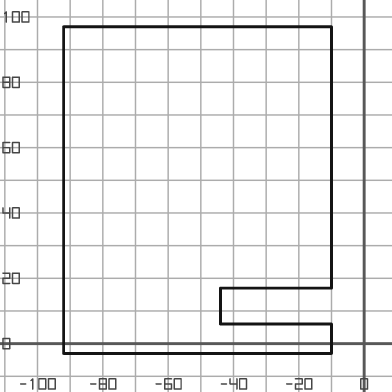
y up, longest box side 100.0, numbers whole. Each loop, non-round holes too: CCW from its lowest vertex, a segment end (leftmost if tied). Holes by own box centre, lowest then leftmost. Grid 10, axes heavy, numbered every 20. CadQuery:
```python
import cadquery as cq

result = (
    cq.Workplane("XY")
    .moveTo(-92.0, -3.0)
    .lineTo(-10.0, -3.0)
    .lineTo(-10.0, 6.0)
    .lineTo(-44.0, 6.0)
    .lineTo(-44.0, 17.0)
    .lineTo(-10.0, 17.0)
    .lineTo(-10.0, 97.0)
    .lineTo(-92.0, 97.0)
    .close()
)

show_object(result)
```